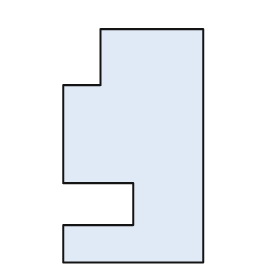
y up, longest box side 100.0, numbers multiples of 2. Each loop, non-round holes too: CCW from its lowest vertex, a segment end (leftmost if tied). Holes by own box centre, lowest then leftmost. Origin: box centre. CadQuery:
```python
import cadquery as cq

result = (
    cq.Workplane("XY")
    .moveTo(-30.0, -50.0)
    .lineTo(30.0, -50.0)
    .lineTo(30.0, 50.0)
    .lineTo(-14.0, 50.0)
    .lineTo(-14.0, 26.0)
    .lineTo(-30.0, 26.0)
    .lineTo(-30.0, -16.0)
    .lineTo(0.0, -16.0)
    .lineTo(0.0, -34.0)
    .lineTo(-30.0, -34.0)
    .close()
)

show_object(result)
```